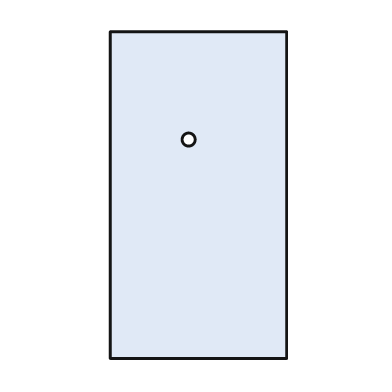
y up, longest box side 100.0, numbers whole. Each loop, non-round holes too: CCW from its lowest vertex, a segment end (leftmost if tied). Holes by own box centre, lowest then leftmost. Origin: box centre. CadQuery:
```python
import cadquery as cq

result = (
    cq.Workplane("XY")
    .moveTo(-27.0, -50.0)
    .lineTo(27.0, -50.0)
    .lineTo(27.0, 50.0)
    .lineTo(-27.0, 50.0)
    .close()
    .moveTo(-3.0, 17.0)
    .circle(2.0)
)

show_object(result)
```